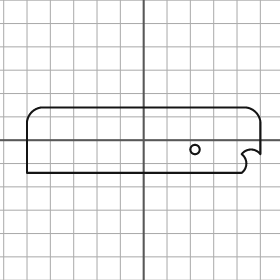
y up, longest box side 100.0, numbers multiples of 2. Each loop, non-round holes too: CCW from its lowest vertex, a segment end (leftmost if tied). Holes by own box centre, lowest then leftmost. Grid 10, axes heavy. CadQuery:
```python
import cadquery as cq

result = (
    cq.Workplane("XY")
    .moveTo(-50.0, -14.0)
    .lineTo(42.0, -14.0)
    .threePointArc((44.0, -10.0), (42.0, -6.0))
    .threePointArc((46.0, -4.0), (50.0, -6.0))
    .lineTo(50.0, 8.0)
    .threePointArc((48.0, 12.0), (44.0, 14.0))
    .lineTo(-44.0, 14.0)
    .threePointArc((-48.0, 12.0), (-50.0, 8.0))
    .close()
    .moveTo(22.0, -4.0)
    .circle(2.0)
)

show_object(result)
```